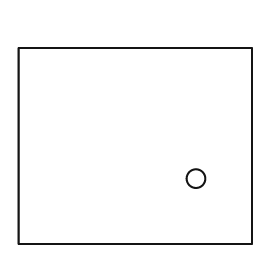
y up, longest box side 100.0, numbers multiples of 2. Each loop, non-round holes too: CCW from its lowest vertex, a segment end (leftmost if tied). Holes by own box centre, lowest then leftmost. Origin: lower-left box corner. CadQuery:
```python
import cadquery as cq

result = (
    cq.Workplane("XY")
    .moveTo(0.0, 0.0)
    .lineTo(100.0, 0.0)
    .lineTo(100.0, 84.0)
    .lineTo(0.0, 84.0)
    .close()
    .moveTo(76.0, 28.0)
    .circle(4.0)
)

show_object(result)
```